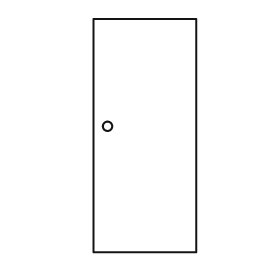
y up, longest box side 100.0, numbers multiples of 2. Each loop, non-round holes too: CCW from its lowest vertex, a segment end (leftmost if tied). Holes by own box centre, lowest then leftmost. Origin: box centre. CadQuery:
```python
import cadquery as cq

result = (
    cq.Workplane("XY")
    .moveTo(-22.0, -50.0)
    .lineTo(22.0, -50.0)
    .lineTo(22.0, 50.0)
    .lineTo(-22.0, 50.0)
    .close()
    .moveTo(-16.0, 4.0)
    .circle(2.0)
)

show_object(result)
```